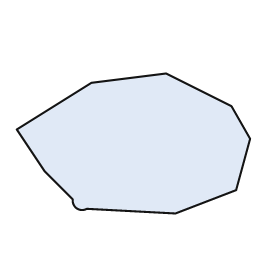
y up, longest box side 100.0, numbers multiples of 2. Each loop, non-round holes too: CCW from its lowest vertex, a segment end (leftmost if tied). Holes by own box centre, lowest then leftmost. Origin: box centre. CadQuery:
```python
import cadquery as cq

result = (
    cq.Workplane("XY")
    .moveTo(18.0, -30.0)
    .lineTo(44.0, -20.0)
    .lineTo(50.0, 2.0)
    .lineTo(42.0, 16.0)
    .lineTo(14.0, 30.0)
    .lineTo(-18.0, 26.0)
    .lineTo(-50.0, 6.0)
    .lineTo(-38.0, -12.0)
    .lineTo(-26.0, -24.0)
    .threePointArc((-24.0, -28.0), (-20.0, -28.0))
    .close()
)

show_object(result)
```